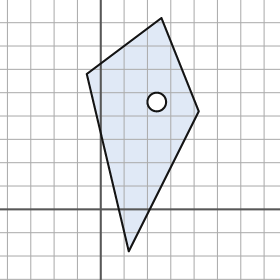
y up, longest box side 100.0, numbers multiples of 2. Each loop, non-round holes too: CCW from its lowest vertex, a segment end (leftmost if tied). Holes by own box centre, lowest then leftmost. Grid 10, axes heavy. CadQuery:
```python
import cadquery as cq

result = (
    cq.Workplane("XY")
    .moveTo(12.0, -18.0)
    .lineTo(42.0, 42.0)
    .lineTo(26.0, 82.0)
    .lineTo(-6.0, 58.0)
    .close()
    .moveTo(24.0, 46.0)
    .circle(4.0)
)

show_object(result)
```